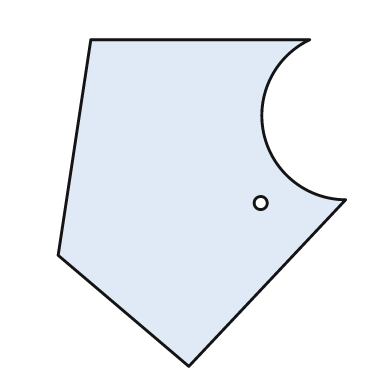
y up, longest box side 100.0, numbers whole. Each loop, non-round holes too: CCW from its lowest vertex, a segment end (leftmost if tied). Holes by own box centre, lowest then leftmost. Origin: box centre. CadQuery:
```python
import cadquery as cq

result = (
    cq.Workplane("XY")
    .moveTo(-4.0, -50.0)
    .lineTo(44.0, 1.0)
    .threePointArc((19.0, 21.0), (33.0, 50.0))
    .lineTo(-34.0, 50.0)
    .lineTo(-44.0, -16.0)
    .close()
    .moveTo(18.0, 0.0)
    .circle(2.0)
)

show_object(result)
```